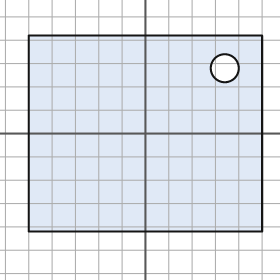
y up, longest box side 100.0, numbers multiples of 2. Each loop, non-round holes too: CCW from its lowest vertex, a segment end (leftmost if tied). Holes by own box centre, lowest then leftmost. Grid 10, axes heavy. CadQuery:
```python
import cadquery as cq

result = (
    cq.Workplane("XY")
    .moveTo(-50.0, -42.0)
    .lineTo(50.0, -42.0)
    .lineTo(50.0, 42.0)
    .lineTo(-50.0, 42.0)
    .close()
    .moveTo(34.0, 28.0)
    .circle(6.0)
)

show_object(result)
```